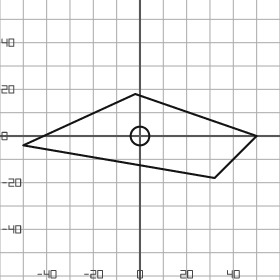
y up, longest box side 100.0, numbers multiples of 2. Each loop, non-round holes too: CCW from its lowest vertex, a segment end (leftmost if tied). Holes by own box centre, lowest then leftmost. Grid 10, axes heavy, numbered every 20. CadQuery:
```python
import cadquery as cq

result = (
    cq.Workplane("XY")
    .moveTo(32.0, -18.0)
    .lineTo(50.0, 0.0)
    .lineTo(-2.0, 18.0)
    .lineTo(-50.0, -4.0)
    .close()
    .moveTo(0.0, 0.0)
    .circle(4.0)
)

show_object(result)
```